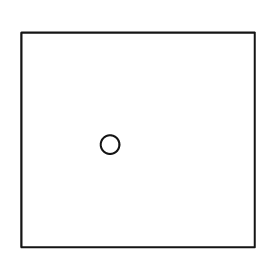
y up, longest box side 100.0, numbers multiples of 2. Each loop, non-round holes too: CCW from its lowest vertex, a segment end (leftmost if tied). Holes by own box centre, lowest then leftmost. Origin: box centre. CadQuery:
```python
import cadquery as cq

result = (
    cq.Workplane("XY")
    .moveTo(-50.0, -46.0)
    .lineTo(50.0, -46.0)
    .lineTo(50.0, 46.0)
    .lineTo(-50.0, 46.0)
    .close()
    .moveTo(-12.0, -2.0)
    .circle(4.0)
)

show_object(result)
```